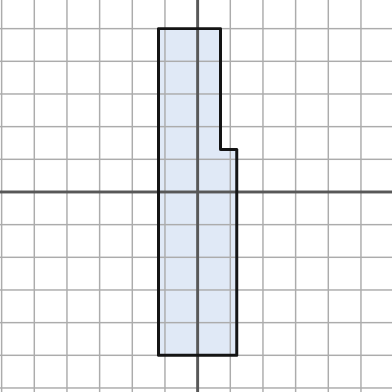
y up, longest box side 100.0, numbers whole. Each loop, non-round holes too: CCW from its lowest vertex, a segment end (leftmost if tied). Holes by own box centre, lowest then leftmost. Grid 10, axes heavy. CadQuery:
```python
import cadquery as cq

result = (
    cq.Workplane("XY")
    .moveTo(-12.0, -50.0)
    .lineTo(12.0, -50.0)
    .lineTo(12.0, 13.0)
    .lineTo(7.0, 13.0)
    .lineTo(7.0, 50.0)
    .lineTo(-12.0, 50.0)
    .close()
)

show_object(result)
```